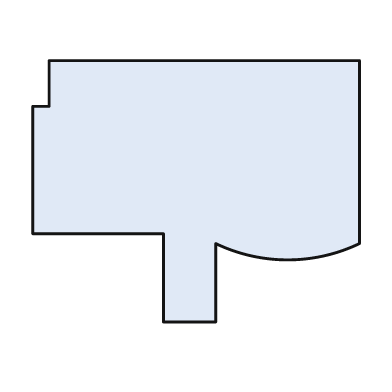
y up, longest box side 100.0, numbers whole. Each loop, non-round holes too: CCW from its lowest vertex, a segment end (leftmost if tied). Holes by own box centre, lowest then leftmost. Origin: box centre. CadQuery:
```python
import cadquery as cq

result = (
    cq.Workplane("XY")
    .moveTo(-10.0, -40.0)
    .lineTo(6.0, -40.0)
    .lineTo(6.0, -16.0)
    .threePointArc((28.0, -21.0), (50.0, -16.0))
    .lineTo(50.0, 40.0)
    .lineTo(-45.0, 40.0)
    .lineTo(-45.0, 26.0)
    .lineTo(-50.0, 26.0)
    .lineTo(-50.0, -13.0)
    .lineTo(-10.0, -13.0)
    .close()
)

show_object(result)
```